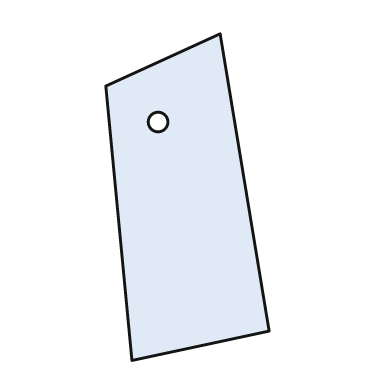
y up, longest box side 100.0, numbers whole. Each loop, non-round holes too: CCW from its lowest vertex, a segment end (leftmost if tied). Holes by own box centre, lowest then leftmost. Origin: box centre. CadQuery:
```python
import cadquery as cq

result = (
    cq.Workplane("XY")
    .moveTo(-17.0, -50.0)
    .lineTo(25.0, -41.0)
    .lineTo(10.0, 50.0)
    .lineTo(-25.0, 34.0)
    .close()
    .moveTo(-9.0, 23.0)
    .circle(3.0)
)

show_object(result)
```